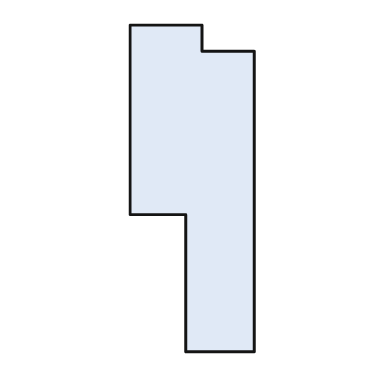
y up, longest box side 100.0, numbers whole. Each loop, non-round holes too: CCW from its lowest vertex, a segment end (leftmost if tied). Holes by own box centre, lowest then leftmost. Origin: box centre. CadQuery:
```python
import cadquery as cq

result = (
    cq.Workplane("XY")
    .moveTo(-2.0, -50.0)
    .lineTo(19.0, -50.0)
    .lineTo(19.0, 42.0)
    .lineTo(3.0, 42.0)
    .lineTo(3.0, 50.0)
    .lineTo(-19.0, 50.0)
    .lineTo(-19.0, -8.0)
    .lineTo(-2.0, -8.0)
    .close()
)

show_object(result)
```